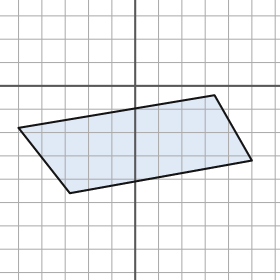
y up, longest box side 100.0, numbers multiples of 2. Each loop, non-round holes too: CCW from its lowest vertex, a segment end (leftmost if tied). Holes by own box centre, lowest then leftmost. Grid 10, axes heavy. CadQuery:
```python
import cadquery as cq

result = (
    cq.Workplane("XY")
    .moveTo(-28.0, -46.0)
    .lineTo(50.0, -32.0)
    .lineTo(34.0, -4.0)
    .lineTo(-50.0, -18.0)
    .close()
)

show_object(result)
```